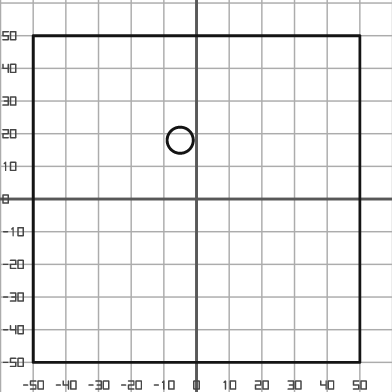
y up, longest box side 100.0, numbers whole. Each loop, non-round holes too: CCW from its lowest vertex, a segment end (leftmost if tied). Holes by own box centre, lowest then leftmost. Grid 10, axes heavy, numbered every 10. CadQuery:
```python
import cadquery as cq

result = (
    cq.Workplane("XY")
    .moveTo(-50.0, -50.0)
    .lineTo(50.0, -50.0)
    .lineTo(50.0, 50.0)
    .lineTo(-50.0, 50.0)
    .close()
    .moveTo(-5.0, 18.0)
    .circle(4.0)
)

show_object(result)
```